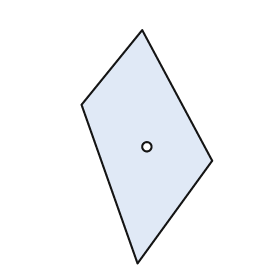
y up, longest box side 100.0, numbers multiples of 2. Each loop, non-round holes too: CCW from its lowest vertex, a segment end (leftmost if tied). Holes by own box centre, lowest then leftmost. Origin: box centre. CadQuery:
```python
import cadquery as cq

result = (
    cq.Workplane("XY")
    .moveTo(-4.0, -50.0)
    .lineTo(28.0, -6.0)
    .lineTo(-2.0, 50.0)
    .lineTo(-28.0, 18.0)
    .close()
    .moveTo(0.0, 0.0)
    .circle(2.0)
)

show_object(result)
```